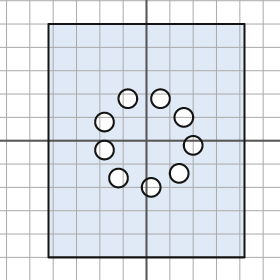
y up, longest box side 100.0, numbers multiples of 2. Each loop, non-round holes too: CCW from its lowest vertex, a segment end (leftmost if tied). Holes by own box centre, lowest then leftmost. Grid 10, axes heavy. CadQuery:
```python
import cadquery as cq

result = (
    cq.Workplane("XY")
    .moveTo(-42.0, -50.0)
    .lineTo(42.0, -50.0)
    .lineTo(42.0, 50.0)
    .lineTo(-42.0, 50.0)
    .close()
    .moveTo(2.0, -20.0)
    .circle(4.0)
    .moveTo(-12.0, -16.0)
    .circle(4.0)
    .moveTo(14.0, -14.0)
    .circle(4.0)
    .moveTo(-18.0, -4.0)
    .circle(4.0)
    .moveTo(20.0, -2.0)
    .circle(4.0)
    .moveTo(-18.0, 8.0)
    .circle(4.0)
    .moveTo(16.0, 10.0)
    .circle(4.0)
    .moveTo(-8.0, 18.0)
    .circle(4.0)
    .moveTo(6.0, 18.0)
    .circle(4.0)
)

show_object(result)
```